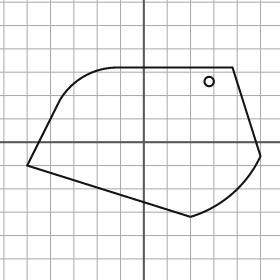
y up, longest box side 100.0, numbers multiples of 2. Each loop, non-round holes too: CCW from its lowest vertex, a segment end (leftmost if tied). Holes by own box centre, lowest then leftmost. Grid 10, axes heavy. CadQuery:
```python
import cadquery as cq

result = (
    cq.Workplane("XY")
    .moveTo(20.0, -32.0)
    .threePointArc((38.0, -22.0), (50.0, -6.0))
    .lineTo(38.0, 32.0)
    .lineTo(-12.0, 32.0)
    .threePointArc((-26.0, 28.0), (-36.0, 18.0))
    .lineTo(-50.0, -10.0)
    .close()
    .moveTo(28.0, 26.0)
    .circle(2.0)
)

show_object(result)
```